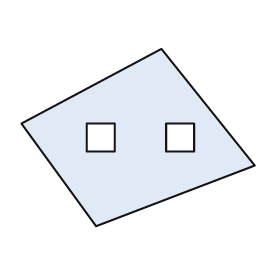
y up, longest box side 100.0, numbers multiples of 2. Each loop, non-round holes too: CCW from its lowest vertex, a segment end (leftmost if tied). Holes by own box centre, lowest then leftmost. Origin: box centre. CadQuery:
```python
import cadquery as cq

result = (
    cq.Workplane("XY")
    .moveTo(-18.0, -38.0)
    .lineTo(50.0, -12.0)
    .lineTo(10.0, 38.0)
    .lineTo(-50.0, 6.0)
    .close()
    .moveTo(-22.0, -6.0)
    .lineTo(-10.0, -6.0)
    .lineTo(-10.0, 6.0)
    .lineTo(-22.0, 6.0)
    .close()
    .moveTo(12.0, -6.0)
    .lineTo(24.0, -6.0)
    .lineTo(24.0, 6.0)
    .lineTo(12.0, 6.0)
    .close()
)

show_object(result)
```